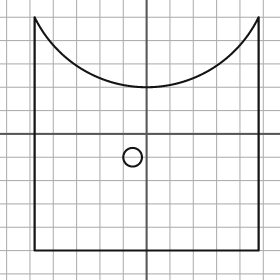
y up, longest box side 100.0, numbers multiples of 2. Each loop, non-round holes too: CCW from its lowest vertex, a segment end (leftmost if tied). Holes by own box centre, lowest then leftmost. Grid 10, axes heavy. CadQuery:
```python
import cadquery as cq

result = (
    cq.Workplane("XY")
    .moveTo(-48.0, -50.0)
    .lineTo(48.0, -50.0)
    .lineTo(48.0, 50.0)
    .threePointArc((0.0, 20.0), (-48.0, 50.0))
    .close()
    .moveTo(-6.0, -10.0)
    .circle(4.0)
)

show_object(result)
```